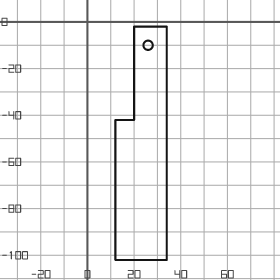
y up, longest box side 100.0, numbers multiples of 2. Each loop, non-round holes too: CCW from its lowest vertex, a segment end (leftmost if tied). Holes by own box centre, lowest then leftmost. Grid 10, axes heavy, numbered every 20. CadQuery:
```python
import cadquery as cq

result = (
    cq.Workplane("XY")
    .moveTo(12.0, -102.0)
    .lineTo(34.0, -102.0)
    .lineTo(34.0, -2.0)
    .lineTo(20.0, -2.0)
    .lineTo(20.0, -42.0)
    .lineTo(12.0, -42.0)
    .close()
    .moveTo(26.0, -10.0)
    .circle(2.0)
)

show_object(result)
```